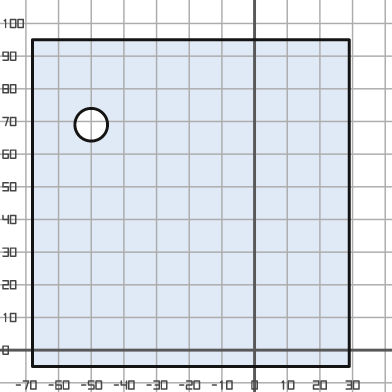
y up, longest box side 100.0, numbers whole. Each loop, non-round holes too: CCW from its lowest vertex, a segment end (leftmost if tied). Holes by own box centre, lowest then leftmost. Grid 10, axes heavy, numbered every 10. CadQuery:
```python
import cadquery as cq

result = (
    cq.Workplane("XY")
    .moveTo(-68.0, -5.0)
    .lineTo(29.0, -5.0)
    .lineTo(29.0, 95.0)
    .lineTo(-68.0, 95.0)
    .close()
    .moveTo(-50.0, 69.0)
    .circle(5.0)
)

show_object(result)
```